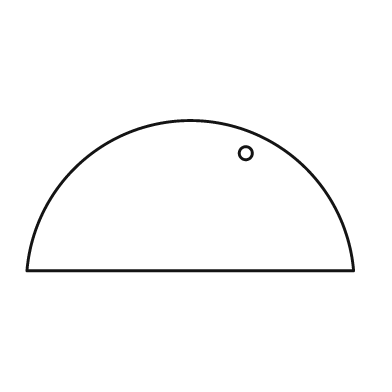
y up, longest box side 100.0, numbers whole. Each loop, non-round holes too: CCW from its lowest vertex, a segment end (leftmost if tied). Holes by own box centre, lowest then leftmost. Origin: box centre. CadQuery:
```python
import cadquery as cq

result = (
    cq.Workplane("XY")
    .moveTo(-50.0, -23.0)
    .lineTo(50.0, -23.0)
    .threePointArc((0.0, 23.0), (-50.0, -23.0))
    .close()
    .moveTo(17.0, 13.0)
    .circle(2.0)
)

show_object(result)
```